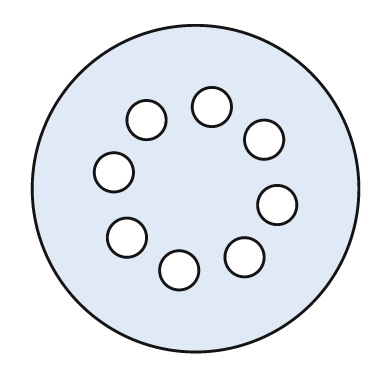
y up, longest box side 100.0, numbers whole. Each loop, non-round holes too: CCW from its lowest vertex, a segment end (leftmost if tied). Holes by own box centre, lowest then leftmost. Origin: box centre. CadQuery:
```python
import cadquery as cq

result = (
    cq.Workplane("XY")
    .moveTo(0.0, 0.0)
    .circle(50.0)
    .moveTo(-5.0, -25.0)
    .circle(6.0)
    .moveTo(15.0, -21.0)
    .circle(6.0)
    .moveTo(-21.0, -15.0)
    .circle(6.0)
    .moveTo(25.0, -5.0)
    .circle(6.0)
    .moveTo(-25.0, 5.0)
    .circle(6.0)
    .moveTo(21.0, 15.0)
    .circle(6.0)
    .moveTo(-15.0, 21.0)
    .circle(6.0)
    .moveTo(5.0, 25.0)
    .circle(6.0)
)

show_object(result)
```